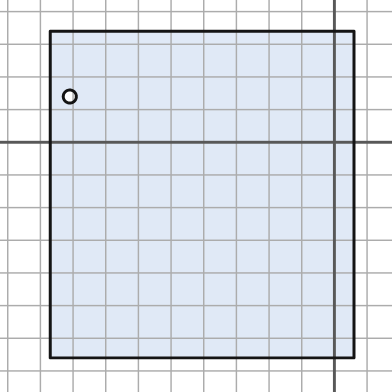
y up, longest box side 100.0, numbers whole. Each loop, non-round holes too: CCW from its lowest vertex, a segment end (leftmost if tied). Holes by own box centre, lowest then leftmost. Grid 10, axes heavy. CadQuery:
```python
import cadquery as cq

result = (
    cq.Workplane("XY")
    .moveTo(-87.0, -66.0)
    .lineTo(6.0, -66.0)
    .lineTo(6.0, 34.0)
    .lineTo(-87.0, 34.0)
    .close()
    .moveTo(-81.0, 14.0)
    .circle(2.0)
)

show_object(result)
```